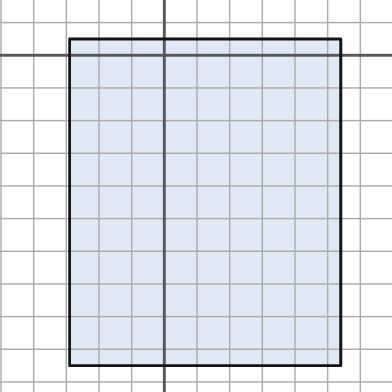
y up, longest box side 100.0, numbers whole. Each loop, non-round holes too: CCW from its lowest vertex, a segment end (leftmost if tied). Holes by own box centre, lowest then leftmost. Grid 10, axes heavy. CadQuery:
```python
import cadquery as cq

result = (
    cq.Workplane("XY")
    .moveTo(-29.0, -95.0)
    .lineTo(54.0, -95.0)
    .lineTo(54.0, 5.0)
    .lineTo(-29.0, 5.0)
    .close()
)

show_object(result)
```